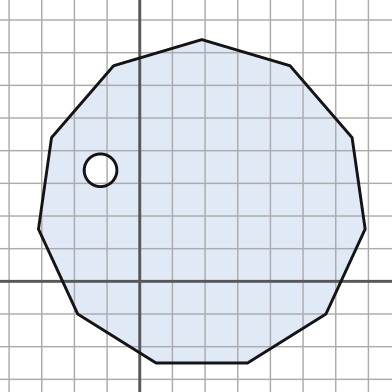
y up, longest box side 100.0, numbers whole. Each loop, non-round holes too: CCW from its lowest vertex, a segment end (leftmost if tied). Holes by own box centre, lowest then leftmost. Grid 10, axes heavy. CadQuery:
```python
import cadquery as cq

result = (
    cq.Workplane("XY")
    .moveTo(5.0, -25.0)
    .lineTo(33.0, -25.0)
    .lineTo(57.0, -10.0)
    .lineTo(69.0, 16.0)
    .lineTo(65.0, 44.0)
    .lineTo(46.0, 66.0)
    .lineTo(19.0, 74.0)
    .lineTo(-8.0, 66.0)
    .lineTo(-27.0, 44.0)
    .lineTo(-31.0, 16.0)
    .lineTo(-19.0, -10.0)
    .close()
    .moveTo(-12.0, 34.0)
    .circle(5.0)
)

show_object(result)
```